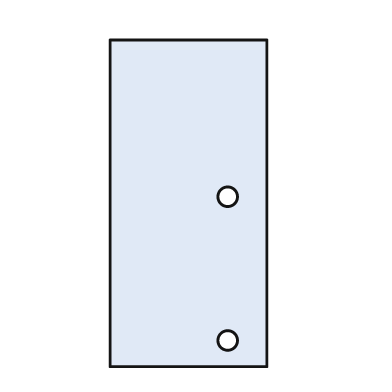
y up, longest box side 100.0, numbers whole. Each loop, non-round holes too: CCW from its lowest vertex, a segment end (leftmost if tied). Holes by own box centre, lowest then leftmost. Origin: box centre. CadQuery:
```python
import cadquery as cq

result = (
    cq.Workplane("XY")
    .moveTo(-24.0, -50.0)
    .lineTo(24.0, -50.0)
    .lineTo(24.0, 50.0)
    .lineTo(-24.0, 50.0)
    .close()
    .moveTo(12.0, -42.0)
    .circle(3.0)
    .moveTo(12.0, 2.0)
    .circle(3.0)
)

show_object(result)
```